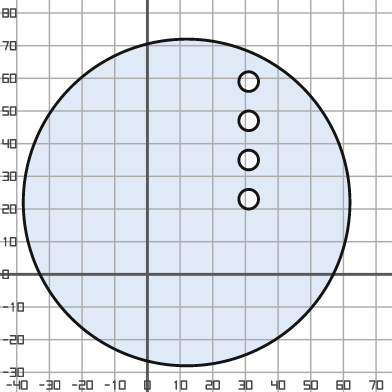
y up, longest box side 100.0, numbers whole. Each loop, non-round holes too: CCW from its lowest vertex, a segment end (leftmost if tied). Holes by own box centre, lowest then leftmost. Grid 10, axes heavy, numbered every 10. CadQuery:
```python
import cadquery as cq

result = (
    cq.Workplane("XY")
    .moveTo(12.0, 22.0)
    .circle(50.0)
    .moveTo(31.0, 23.0)
    .circle(3.0)
    .moveTo(31.0, 35.0)
    .circle(3.0)
    .moveTo(31.0, 47.0)
    .circle(3.0)
    .moveTo(31.0, 59.0)
    .circle(3.0)
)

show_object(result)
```